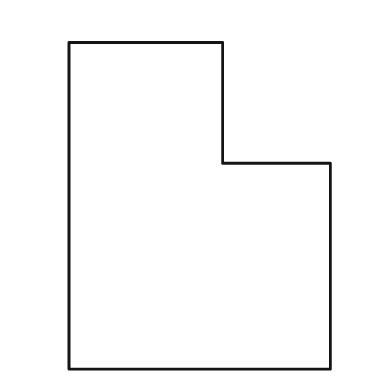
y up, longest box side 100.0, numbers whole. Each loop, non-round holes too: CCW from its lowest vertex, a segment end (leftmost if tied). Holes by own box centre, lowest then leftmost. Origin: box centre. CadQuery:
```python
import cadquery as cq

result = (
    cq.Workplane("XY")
    .moveTo(-40.0, -50.0)
    .lineTo(40.0, -50.0)
    .lineTo(40.0, 13.0)
    .lineTo(7.0, 13.0)
    .lineTo(7.0, 50.0)
    .lineTo(-40.0, 50.0)
    .close()
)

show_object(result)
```